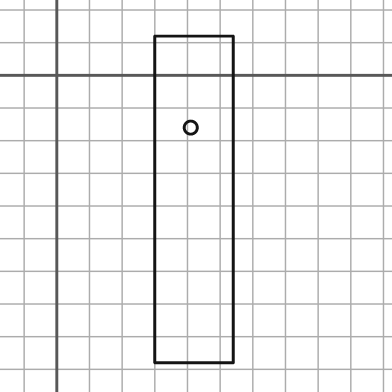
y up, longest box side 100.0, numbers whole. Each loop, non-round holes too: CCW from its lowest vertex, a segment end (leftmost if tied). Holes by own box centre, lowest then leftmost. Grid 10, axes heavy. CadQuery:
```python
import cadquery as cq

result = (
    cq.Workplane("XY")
    .moveTo(30.0, -88.0)
    .lineTo(54.0, -88.0)
    .lineTo(54.0, 12.0)
    .lineTo(30.0, 12.0)
    .close()
    .moveTo(41.0, -16.0)
    .circle(2.0)
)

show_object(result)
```